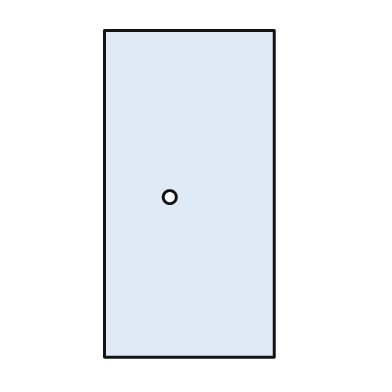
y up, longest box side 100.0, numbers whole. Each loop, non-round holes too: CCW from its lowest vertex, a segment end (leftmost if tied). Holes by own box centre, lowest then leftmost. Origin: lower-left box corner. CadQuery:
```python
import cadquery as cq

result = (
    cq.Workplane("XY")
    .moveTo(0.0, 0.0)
    .lineTo(52.0, 0.0)
    .lineTo(52.0, 100.0)
    .lineTo(0.0, 100.0)
    .close()
    .moveTo(20.0, 49.0)
    .circle(2.0)
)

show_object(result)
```